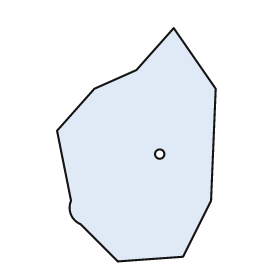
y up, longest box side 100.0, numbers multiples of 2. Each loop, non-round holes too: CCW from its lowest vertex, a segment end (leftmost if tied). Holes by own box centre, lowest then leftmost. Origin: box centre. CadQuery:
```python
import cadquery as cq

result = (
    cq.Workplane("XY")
    .moveTo(-8.0, -50.0)
    .lineTo(20.0, -48.0)
    .lineTo(32.0, -24.0)
    .lineTo(34.0, 24.0)
    .lineTo(16.0, 50.0)
    .lineTo(0.0, 32.0)
    .lineTo(-18.0, 24.0)
    .lineTo(-34.0, 6.0)
    .lineTo(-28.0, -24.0)
    .threePointArc((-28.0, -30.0), (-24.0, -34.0))
    .close()
    .moveTo(10.0, -4.0)
    .circle(2.0)
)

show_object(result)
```